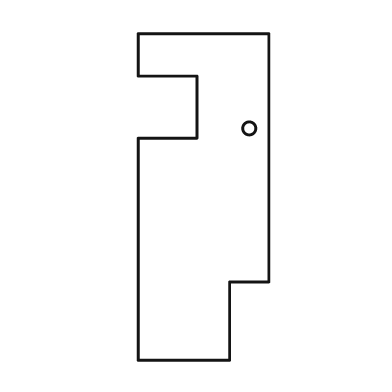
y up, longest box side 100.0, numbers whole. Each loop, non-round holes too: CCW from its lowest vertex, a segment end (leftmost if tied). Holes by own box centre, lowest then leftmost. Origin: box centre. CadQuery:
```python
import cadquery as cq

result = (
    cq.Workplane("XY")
    .moveTo(-20.0, -50.0)
    .lineTo(8.0, -50.0)
    .lineTo(8.0, -26.0)
    .lineTo(20.0, -26.0)
    .lineTo(20.0, 50.0)
    .lineTo(-20.0, 50.0)
    .lineTo(-20.0, 37.0)
    .lineTo(-2.0, 37.0)
    .lineTo(-2.0, 18.0)
    .lineTo(-20.0, 18.0)
    .close()
    .moveTo(14.0, 21.0)
    .circle(2.0)
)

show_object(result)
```